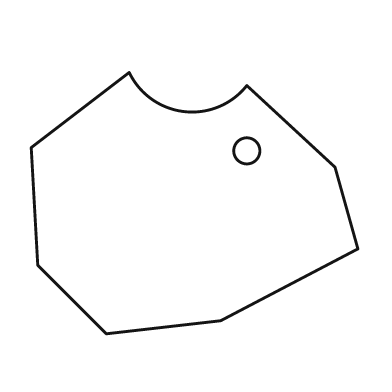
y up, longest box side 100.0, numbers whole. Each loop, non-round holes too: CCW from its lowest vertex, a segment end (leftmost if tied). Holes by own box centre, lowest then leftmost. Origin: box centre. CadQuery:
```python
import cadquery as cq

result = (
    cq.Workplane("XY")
    .moveTo(-27.0, -40.0)
    .lineTo(8.0, -36.0)
    .lineTo(50.0, -14.0)
    .lineTo(43.0, 11.0)
    .lineTo(16.0, 36.0)
    .threePointArc((-3.0, 28.0), (-20.0, 40.0))
    .lineTo(-50.0, 17.0)
    .lineTo(-48.0, -19.0)
    .close()
    .moveTo(16.0, 16.0)
    .circle(4.0)
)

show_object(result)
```